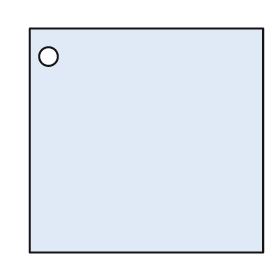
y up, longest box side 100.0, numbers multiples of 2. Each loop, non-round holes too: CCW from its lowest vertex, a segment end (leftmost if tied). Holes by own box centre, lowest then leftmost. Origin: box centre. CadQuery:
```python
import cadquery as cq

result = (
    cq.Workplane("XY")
    .moveTo(-50.0, -48.0)
    .lineTo(50.0, -48.0)
    .lineTo(50.0, 48.0)
    .lineTo(-50.0, 48.0)
    .close()
    .moveTo(-42.0, 36.0)
    .circle(4.0)
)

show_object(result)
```